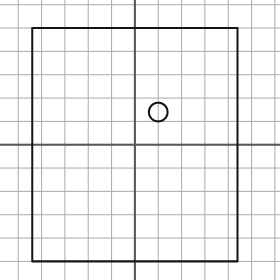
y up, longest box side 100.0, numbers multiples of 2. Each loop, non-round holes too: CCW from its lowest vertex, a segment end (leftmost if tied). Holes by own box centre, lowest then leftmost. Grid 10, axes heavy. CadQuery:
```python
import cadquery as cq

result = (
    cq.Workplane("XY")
    .moveTo(-44.0, -50.0)
    .lineTo(44.0, -50.0)
    .lineTo(44.0, 50.0)
    .lineTo(-44.0, 50.0)
    .close()
    .moveTo(10.0, 14.0)
    .circle(4.0)
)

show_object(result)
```